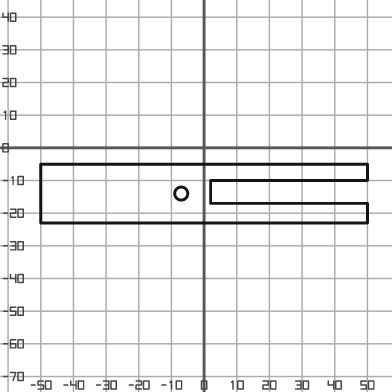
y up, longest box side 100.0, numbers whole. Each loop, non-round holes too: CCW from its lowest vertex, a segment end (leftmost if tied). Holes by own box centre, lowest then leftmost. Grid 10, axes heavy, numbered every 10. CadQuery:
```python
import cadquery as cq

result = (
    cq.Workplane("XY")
    .moveTo(-50.0, -23.0)
    .lineTo(50.0, -23.0)
    .lineTo(50.0, -17.0)
    .lineTo(2.0, -17.0)
    .lineTo(2.0, -10.0)
    .lineTo(50.0, -10.0)
    .lineTo(50.0, -5.0)
    .lineTo(-50.0, -5.0)
    .close()
    .moveTo(-7.0, -14.0)
    .circle(2.0)
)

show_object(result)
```